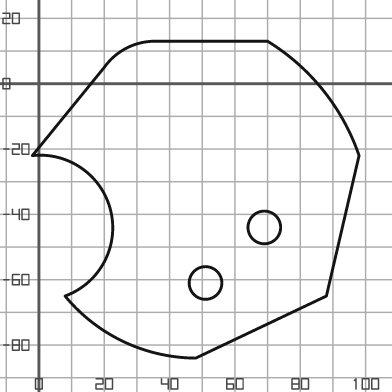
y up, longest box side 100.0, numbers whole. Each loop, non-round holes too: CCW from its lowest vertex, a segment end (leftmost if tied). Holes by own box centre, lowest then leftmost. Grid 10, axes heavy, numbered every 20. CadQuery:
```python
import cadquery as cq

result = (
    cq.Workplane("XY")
    .moveTo(48.0, -84.0)
    .lineTo(88.0, -65.0)
    .lineTo(98.0, -22.0)
    .threePointArc((87.0, -2.0), (70.0, 13.0))
    .lineTo(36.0, 13.0)
    .threePointArc((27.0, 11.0), (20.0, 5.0))
    .lineTo(-2.0, -22.0)
    .threePointArc((22.0, -39.0), (8.0, -65.0))
    .threePointArc((26.0, -79.0), (48.0, -84.0))
    .close()
    .moveTo(51.0, -61.0)
    .circle(5.0)
    .moveTo(69.0, -44.0)
    .circle(5.0)
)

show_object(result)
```